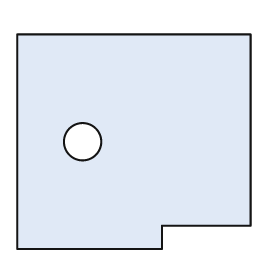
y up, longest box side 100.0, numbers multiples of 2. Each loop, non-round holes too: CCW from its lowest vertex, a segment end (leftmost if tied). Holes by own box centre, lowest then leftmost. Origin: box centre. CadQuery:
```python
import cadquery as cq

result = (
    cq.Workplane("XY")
    .moveTo(-50.0, -46.0)
    .lineTo(12.0, -46.0)
    .lineTo(12.0, -36.0)
    .lineTo(50.0, -36.0)
    .lineTo(50.0, 46.0)
    .lineTo(-50.0, 46.0)
    .close()
    .moveTo(-22.0, 0.0)
    .circle(8.0)
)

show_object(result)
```